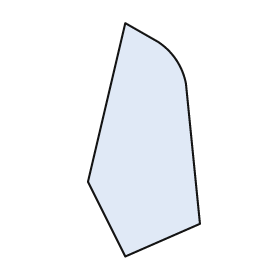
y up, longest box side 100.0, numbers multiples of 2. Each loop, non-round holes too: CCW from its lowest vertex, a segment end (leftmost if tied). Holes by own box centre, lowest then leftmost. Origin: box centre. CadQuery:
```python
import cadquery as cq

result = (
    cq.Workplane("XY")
    .moveTo(-8.0, -50.0)
    .lineTo(24.0, -36.0)
    .lineTo(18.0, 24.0)
    .threePointArc((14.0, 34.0), (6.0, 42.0))
    .lineTo(-8.0, 50.0)
    .lineTo(-24.0, -18.0)
    .close()
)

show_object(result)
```